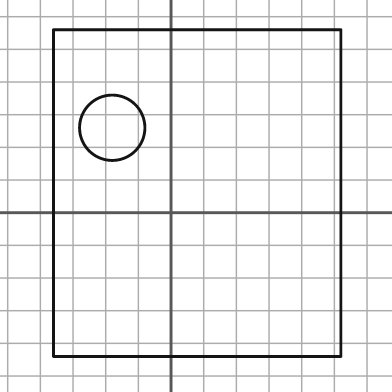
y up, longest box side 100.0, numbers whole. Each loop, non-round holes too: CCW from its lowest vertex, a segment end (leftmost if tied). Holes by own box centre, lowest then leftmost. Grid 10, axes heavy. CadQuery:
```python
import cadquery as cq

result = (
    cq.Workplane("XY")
    .moveTo(-36.0, -44.0)
    .lineTo(52.0, -44.0)
    .lineTo(52.0, 56.0)
    .lineTo(-36.0, 56.0)
    .close()
    .moveTo(-18.0, 26.0)
    .circle(10.0)
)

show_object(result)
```